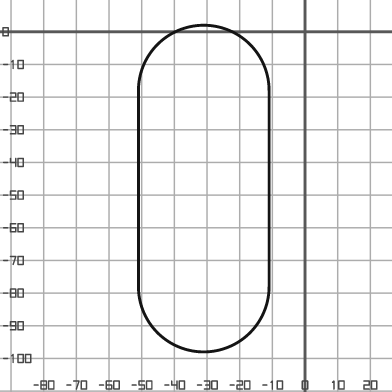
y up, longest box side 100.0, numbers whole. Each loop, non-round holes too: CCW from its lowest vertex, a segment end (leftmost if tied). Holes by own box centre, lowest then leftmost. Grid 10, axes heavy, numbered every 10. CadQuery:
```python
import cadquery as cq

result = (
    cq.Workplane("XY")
    .moveTo(-51.0, -78.0)
    .threePointArc((-31.0, -98.0), (-11.0, -78.0))
    .lineTo(-11.0, -18.0)
    .threePointArc((-31.0, 2.0), (-51.0, -18.0))
    .close()
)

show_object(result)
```